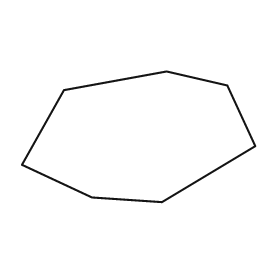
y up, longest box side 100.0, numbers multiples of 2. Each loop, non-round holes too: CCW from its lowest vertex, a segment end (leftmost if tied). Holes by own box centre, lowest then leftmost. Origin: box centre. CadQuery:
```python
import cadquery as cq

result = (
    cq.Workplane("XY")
    .moveTo(10.0, -28.0)
    .lineTo(50.0, -4.0)
    .lineTo(38.0, 22.0)
    .lineTo(12.0, 28.0)
    .lineTo(-32.0, 20.0)
    .lineTo(-50.0, -12.0)
    .lineTo(-20.0, -26.0)
    .close()
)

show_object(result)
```